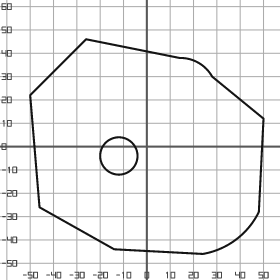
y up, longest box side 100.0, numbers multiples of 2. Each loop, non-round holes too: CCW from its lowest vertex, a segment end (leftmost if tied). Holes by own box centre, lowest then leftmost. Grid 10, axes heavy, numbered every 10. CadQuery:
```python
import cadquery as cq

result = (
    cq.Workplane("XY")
    .moveTo(24.0, -46.0)
    .threePointArc((38.0, -40.0), (48.0, -28.0))
    .lineTo(50.0, 12.0)
    .lineTo(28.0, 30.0)
    .threePointArc((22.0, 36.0), (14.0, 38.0))
    .lineTo(-26.0, 46.0)
    .lineTo(-50.0, 22.0)
    .lineTo(-46.0, -26.0)
    .lineTo(-14.0, -44.0)
    .close()
    .moveTo(-12.0, -4.0)
    .circle(8.0)
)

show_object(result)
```